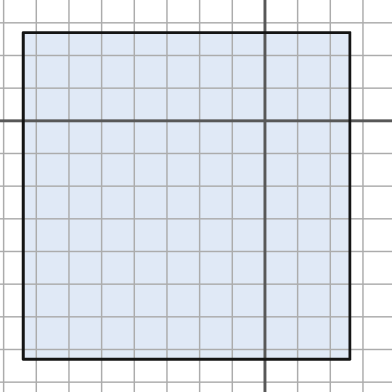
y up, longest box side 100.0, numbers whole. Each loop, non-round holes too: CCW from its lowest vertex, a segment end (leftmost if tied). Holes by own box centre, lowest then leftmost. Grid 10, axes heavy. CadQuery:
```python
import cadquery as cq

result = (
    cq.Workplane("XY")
    .moveTo(-74.0, -73.0)
    .lineTo(26.0, -73.0)
    .lineTo(26.0, 27.0)
    .lineTo(-74.0, 27.0)
    .close()
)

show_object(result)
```